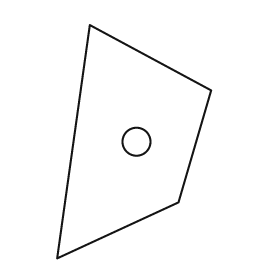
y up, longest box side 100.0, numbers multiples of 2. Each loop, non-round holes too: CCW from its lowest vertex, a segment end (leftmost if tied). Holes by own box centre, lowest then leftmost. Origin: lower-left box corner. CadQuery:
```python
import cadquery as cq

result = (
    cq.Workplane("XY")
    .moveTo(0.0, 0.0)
    .lineTo(52.0, 24.0)
    .lineTo(66.0, 72.0)
    .lineTo(14.0, 100.0)
    .close()
    .moveTo(34.0, 50.0)
    .circle(6.0)
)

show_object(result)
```